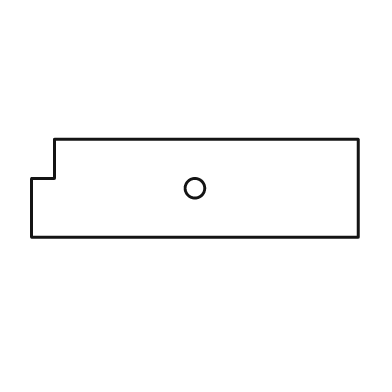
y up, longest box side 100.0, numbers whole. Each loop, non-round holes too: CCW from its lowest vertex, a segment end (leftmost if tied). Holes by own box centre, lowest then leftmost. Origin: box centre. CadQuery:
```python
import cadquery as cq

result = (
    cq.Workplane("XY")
    .moveTo(-50.0, -15.0)
    .lineTo(50.0, -15.0)
    .lineTo(50.0, 15.0)
    .lineTo(-43.0, 15.0)
    .lineTo(-43.0, 3.0)
    .lineTo(-50.0, 3.0)
    .close()
    .moveTo(0.0, 0.0)
    .circle(3.0)
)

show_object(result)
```